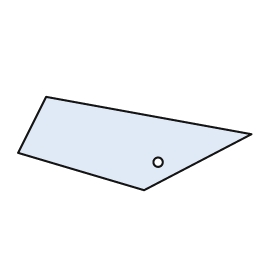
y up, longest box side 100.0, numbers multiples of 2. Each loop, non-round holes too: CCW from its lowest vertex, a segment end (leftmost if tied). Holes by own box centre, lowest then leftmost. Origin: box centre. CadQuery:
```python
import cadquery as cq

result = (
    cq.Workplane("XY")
    .moveTo(4.0, -20.0)
    .lineTo(50.0, 4.0)
    .lineTo(-38.0, 20.0)
    .lineTo(-50.0, -4.0)
    .close()
    .moveTo(10.0, -8.0)
    .circle(2.0)
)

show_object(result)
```